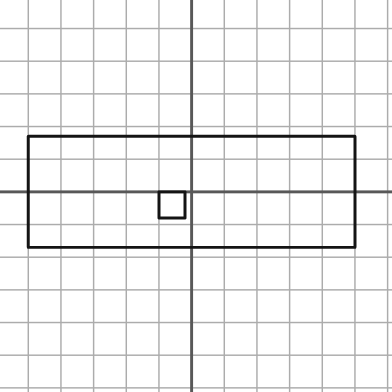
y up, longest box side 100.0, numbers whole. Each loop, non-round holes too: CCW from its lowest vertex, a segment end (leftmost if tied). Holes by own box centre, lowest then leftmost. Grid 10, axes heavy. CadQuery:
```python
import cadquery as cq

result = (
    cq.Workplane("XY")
    .moveTo(-50.0, -17.0)
    .lineTo(50.0, -17.0)
    .lineTo(50.0, 17.0)
    .lineTo(-50.0, 17.0)
    .close()
    .moveTo(-10.0, -8.0)
    .lineTo(-2.0, -8.0)
    .lineTo(-2.0, 0.0)
    .lineTo(-10.0, 0.0)
    .close()
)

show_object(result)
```